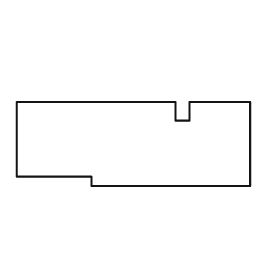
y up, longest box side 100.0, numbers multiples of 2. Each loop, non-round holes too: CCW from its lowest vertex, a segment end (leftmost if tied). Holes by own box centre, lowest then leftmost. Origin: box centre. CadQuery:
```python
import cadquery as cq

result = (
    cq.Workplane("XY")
    .moveTo(-18.0, -18.0)
    .lineTo(50.0, -18.0)
    .lineTo(50.0, 18.0)
    .lineTo(24.0, 18.0)
    .lineTo(24.0, 10.0)
    .lineTo(18.0, 10.0)
    .lineTo(18.0, 18.0)
    .lineTo(-50.0, 18.0)
    .lineTo(-50.0, -14.0)
    .lineTo(-18.0, -14.0)
    .close()
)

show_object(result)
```